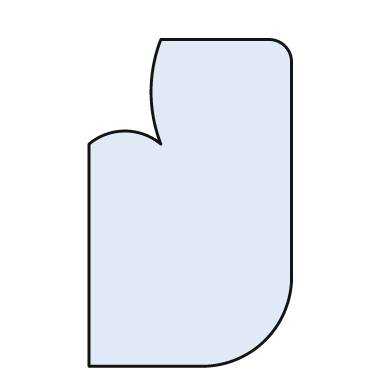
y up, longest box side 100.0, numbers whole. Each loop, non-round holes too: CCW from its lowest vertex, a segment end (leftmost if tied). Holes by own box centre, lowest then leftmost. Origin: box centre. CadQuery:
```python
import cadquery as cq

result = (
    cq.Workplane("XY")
    .moveTo(-31.0, -50.0)
    .lineTo(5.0, -50.0)
    .threePointArc((23.0, -42.0), (31.0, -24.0))
    .lineTo(31.0, 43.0)
    .threePointArc((29.0, 48.0), (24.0, 50.0))
    .lineTo(-9.0, 50.0)
    .threePointArc((-12.0, 34.0), (-9.0, 18.0))
    .threePointArc((-20.0, 22.0), (-31.0, 18.0))
    .close()
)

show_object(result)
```